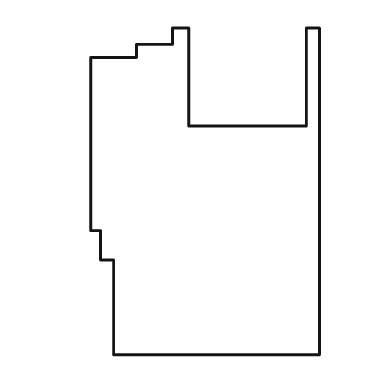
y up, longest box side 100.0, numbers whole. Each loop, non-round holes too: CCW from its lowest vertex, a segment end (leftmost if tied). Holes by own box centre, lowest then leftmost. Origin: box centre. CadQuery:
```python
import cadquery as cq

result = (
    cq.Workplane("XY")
    .moveTo(-28.0, -50.0)
    .lineTo(35.0, -50.0)
    .lineTo(35.0, 50.0)
    .lineTo(31.0, 50.0)
    .lineTo(31.0, 20.0)
    .lineTo(-5.0, 20.0)
    .lineTo(-5.0, 50.0)
    .lineTo(-10.0, 50.0)
    .lineTo(-10.0, 45.0)
    .lineTo(-21.0, 45.0)
    .lineTo(-21.0, 41.0)
    .lineTo(-35.0, 41.0)
    .lineTo(-35.0, -12.0)
    .lineTo(-32.0, -12.0)
    .lineTo(-32.0, -21.0)
    .lineTo(-28.0, -21.0)
    .close()
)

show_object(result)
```